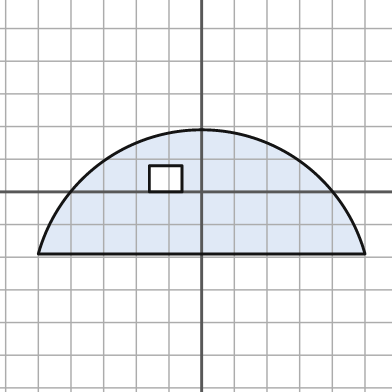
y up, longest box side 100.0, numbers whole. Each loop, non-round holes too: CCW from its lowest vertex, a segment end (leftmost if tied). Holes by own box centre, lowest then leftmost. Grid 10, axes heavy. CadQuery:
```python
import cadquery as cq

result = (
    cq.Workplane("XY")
    .moveTo(-50.0, -19.0)
    .lineTo(50.0, -19.0)
    .threePointArc((0.0, 19.0), (-50.0, -19.0))
    .close()
    .moveTo(-16.0, 0.0)
    .lineTo(-6.0, 0.0)
    .lineTo(-6.0, 8.0)
    .lineTo(-16.0, 8.0)
    .close()
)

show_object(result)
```